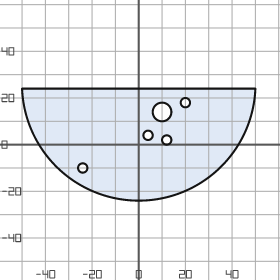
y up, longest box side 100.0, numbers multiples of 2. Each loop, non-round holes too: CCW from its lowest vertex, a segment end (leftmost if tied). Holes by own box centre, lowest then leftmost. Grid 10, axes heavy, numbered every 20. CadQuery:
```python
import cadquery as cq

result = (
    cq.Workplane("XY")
    .moveTo(-50.0, 24.0)
    .threePointArc((0.0, -24.0), (50.0, 24.0))
    .close()
    .moveTo(-24.0, -10.0)
    .circle(2.0)
    .moveTo(12.0, 2.0)
    .circle(2.0)
    .moveTo(4.0, 4.0)
    .circle(2.0)
    .moveTo(10.0, 14.0)
    .circle(4.0)
    .moveTo(20.0, 18.0)
    .circle(2.0)
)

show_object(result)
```